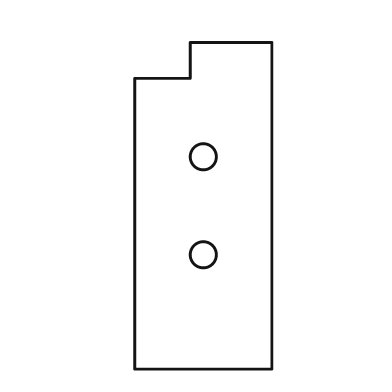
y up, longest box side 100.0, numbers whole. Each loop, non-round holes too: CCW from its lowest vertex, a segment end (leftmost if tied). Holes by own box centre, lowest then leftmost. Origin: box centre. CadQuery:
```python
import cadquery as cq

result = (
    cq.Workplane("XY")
    .moveTo(-21.0, -50.0)
    .lineTo(21.0, -50.0)
    .lineTo(21.0, 50.0)
    .lineTo(-4.0, 50.0)
    .lineTo(-4.0, 39.0)
    .lineTo(-21.0, 39.0)
    .close()
    .moveTo(0.0, -15.0)
    .circle(4.0)
    .moveTo(0.0, 15.0)
    .circle(4.0)
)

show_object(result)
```